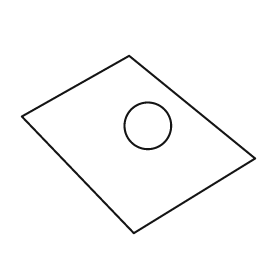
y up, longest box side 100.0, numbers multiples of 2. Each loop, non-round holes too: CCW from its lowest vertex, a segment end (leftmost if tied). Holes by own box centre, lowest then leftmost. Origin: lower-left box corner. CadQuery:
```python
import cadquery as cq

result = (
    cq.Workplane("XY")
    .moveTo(48.0, 0.0)
    .lineTo(100.0, 32.0)
    .lineTo(46.0, 76.0)
    .lineTo(0.0, 50.0)
    .close()
    .moveTo(54.0, 46.0)
    .circle(10.0)
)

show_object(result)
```